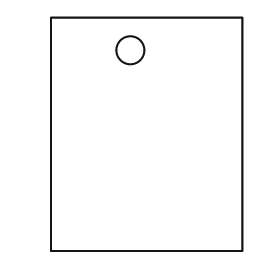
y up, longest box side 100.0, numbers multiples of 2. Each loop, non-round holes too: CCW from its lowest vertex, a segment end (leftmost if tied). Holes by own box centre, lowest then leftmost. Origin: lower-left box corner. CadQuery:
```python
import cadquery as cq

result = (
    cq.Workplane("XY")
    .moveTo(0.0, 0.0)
    .lineTo(82.0, 0.0)
    .lineTo(82.0, 100.0)
    .lineTo(0.0, 100.0)
    .close()
    .moveTo(34.0, 86.0)
    .circle(6.0)
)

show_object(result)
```